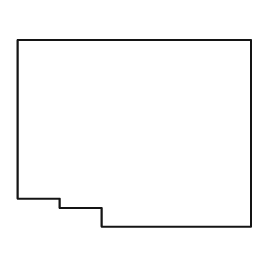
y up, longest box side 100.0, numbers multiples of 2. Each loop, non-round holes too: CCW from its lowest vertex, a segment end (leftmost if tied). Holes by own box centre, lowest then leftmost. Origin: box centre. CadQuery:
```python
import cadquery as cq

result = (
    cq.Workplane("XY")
    .moveTo(-14.0, -40.0)
    .lineTo(50.0, -40.0)
    .lineTo(50.0, 40.0)
    .lineTo(-50.0, 40.0)
    .lineTo(-50.0, -28.0)
    .lineTo(-32.0, -28.0)
    .lineTo(-32.0, -32.0)
    .lineTo(-14.0, -32.0)
    .close()
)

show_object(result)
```